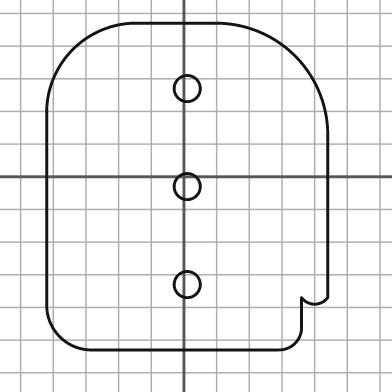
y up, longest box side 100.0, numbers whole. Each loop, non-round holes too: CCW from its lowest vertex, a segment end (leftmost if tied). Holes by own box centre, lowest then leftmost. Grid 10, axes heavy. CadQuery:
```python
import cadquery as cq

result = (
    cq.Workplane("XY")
    .moveTo(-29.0, -53.0)
    .lineTo(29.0, -53.0)
    .threePointArc((34.0, -51.0), (36.0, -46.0))
    .lineTo(36.0, -37.0)
    .threePointArc((40.0, -39.0), (44.0, -37.0))
    .lineTo(44.0, 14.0)
    .threePointArc((34.0, 37.0), (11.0, 47.0))
    .lineTo(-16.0, 47.0)
    .threePointArc((-34.0, 39.0), (-42.0, 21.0))
    .lineTo(-42.0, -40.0)
    .threePointArc((-38.0, -49.0), (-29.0, -53.0))
    .close()
    .moveTo(1.0, -33.0)
    .circle(4.0)
    .moveTo(1.0, -3.0)
    .circle(4.0)
    .moveTo(1.0, 27.0)
    .circle(4.0)
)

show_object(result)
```